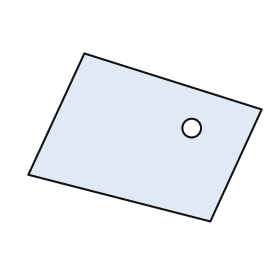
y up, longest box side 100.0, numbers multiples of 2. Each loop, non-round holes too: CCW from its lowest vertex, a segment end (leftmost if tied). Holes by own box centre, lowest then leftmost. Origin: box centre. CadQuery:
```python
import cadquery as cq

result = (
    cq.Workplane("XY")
    .moveTo(28.0, -36.0)
    .lineTo(50.0, 12.0)
    .lineTo(-26.0, 36.0)
    .lineTo(-50.0, -16.0)
    .close()
    .moveTo(20.0, 4.0)
    .circle(4.0)
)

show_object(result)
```